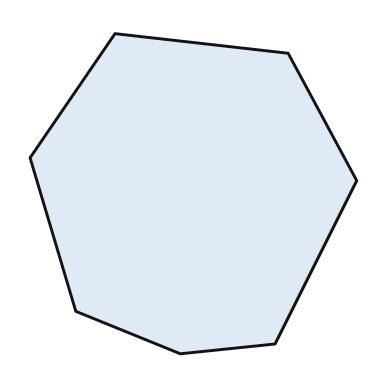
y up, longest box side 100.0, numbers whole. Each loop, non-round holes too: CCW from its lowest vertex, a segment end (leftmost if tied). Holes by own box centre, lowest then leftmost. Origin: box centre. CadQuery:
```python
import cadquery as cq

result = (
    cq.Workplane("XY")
    .moveTo(-4.0, -49.0)
    .lineTo(25.0, -46.0)
    .lineTo(50.0, 4.0)
    .lineTo(29.0, 43.0)
    .lineTo(-24.0, 49.0)
    .lineTo(-50.0, 11.0)
    .lineTo(-36.0, -36.0)
    .close()
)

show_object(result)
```